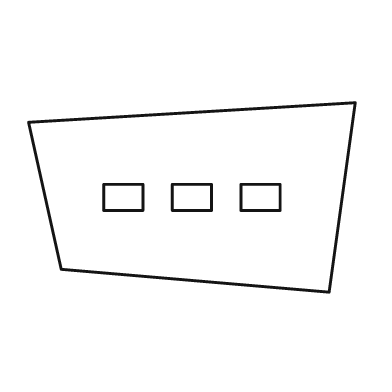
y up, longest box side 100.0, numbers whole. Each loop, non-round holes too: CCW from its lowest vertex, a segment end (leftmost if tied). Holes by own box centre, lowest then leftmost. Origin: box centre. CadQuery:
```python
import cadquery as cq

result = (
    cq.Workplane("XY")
    .moveTo(42.0, -29.0)
    .lineTo(50.0, 29.0)
    .lineTo(-50.0, 23.0)
    .lineTo(-40.0, -22.0)
    .close()
    .moveTo(-27.0, -4.0)
    .lineTo(-15.0, -4.0)
    .lineTo(-15.0, 4.0)
    .lineTo(-27.0, 4.0)
    .close()
    .moveTo(-6.0, -4.0)
    .lineTo(6.0, -4.0)
    .lineTo(6.0, 4.0)
    .lineTo(-6.0, 4.0)
    .close()
    .moveTo(15.0, -4.0)
    .lineTo(27.0, -4.0)
    .lineTo(27.0, 4.0)
    .lineTo(15.0, 4.0)
    .close()
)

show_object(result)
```